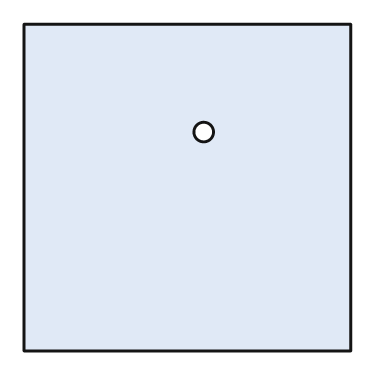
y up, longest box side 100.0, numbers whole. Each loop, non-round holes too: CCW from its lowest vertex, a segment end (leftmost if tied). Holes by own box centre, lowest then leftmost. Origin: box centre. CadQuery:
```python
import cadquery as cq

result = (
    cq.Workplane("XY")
    .moveTo(-50.0, -50.0)
    .lineTo(50.0, -50.0)
    .lineTo(50.0, 50.0)
    .lineTo(-50.0, 50.0)
    .close()
    .moveTo(5.0, 17.0)
    .circle(3.0)
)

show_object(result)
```